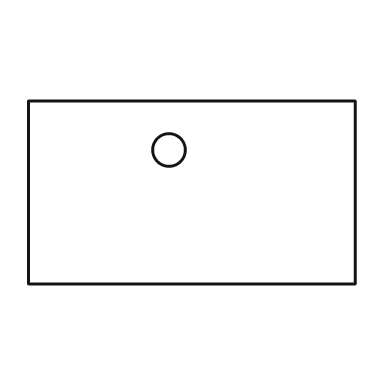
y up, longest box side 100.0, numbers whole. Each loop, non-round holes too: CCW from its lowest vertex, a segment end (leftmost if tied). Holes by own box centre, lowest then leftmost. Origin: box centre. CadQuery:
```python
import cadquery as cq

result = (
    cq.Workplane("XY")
    .moveTo(-50.0, -28.0)
    .lineTo(50.0, -28.0)
    .lineTo(50.0, 28.0)
    .lineTo(-50.0, 28.0)
    .close()
    .moveTo(-7.0, 13.0)
    .circle(5.0)
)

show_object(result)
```